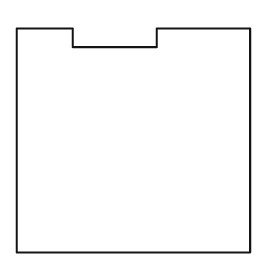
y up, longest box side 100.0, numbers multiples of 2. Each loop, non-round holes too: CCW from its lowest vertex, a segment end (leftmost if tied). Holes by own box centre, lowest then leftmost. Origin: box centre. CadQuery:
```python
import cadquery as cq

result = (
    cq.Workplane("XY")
    .moveTo(-50.0, -48.0)
    .lineTo(50.0, -48.0)
    .lineTo(50.0, 48.0)
    .lineTo(10.0, 48.0)
    .lineTo(10.0, 40.0)
    .lineTo(-26.0, 40.0)
    .lineTo(-26.0, 48.0)
    .lineTo(-50.0, 48.0)
    .close()
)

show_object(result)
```